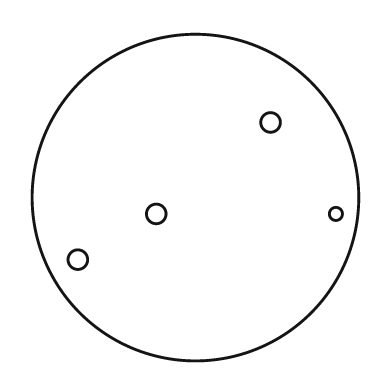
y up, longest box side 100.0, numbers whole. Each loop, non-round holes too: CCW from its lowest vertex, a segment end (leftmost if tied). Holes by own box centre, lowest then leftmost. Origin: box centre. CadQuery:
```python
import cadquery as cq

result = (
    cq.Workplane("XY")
    .moveTo(0.0, 0.0)
    .circle(50.0)
    .moveTo(-36.0, -19.0)
    .circle(3.0)
    .moveTo(-12.0, -5.0)
    .circle(3.0)
    .moveTo(43.0, -5.0)
    .circle(2.0)
    .moveTo(23.0, 23.0)
    .circle(3.0)
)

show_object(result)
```